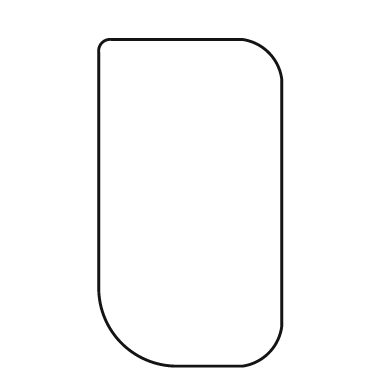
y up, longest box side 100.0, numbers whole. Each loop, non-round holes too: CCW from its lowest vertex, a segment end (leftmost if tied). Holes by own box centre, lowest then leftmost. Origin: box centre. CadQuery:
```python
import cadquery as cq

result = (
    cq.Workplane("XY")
    .moveTo(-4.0, -50.0)
    .lineTo(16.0, -50.0)
    .threePointArc((24.0, -46.0), (28.0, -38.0))
    .lineTo(28.0, 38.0)
    .threePointArc((24.0, 46.0), (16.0, 50.0))
    .lineTo(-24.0, 50.0)
    .threePointArc((-27.0, 49.0), (-28.0, 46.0))
    .lineTo(-28.0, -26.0)
    .threePointArc((-21.0, -43.0), (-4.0, -50.0))
    .close()
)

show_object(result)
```